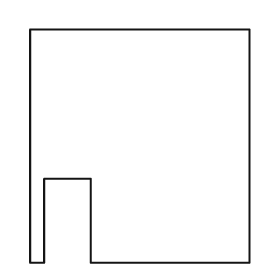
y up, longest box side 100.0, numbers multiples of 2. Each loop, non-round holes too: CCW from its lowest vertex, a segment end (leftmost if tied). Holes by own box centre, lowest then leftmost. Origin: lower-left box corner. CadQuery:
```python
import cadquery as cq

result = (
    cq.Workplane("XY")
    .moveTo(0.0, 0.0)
    .lineTo(6.0, 0.0)
    .lineTo(6.0, 36.0)
    .lineTo(26.0, 36.0)
    .lineTo(26.0, 0.0)
    .lineTo(94.0, 0.0)
    .lineTo(94.0, 100.0)
    .lineTo(0.0, 100.0)
    .close()
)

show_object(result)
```